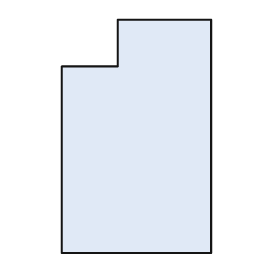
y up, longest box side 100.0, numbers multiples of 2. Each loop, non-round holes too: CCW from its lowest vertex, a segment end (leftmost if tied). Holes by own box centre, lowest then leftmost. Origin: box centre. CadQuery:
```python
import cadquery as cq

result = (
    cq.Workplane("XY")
    .moveTo(-32.0, -50.0)
    .lineTo(32.0, -50.0)
    .lineTo(32.0, 50.0)
    .lineTo(-8.0, 50.0)
    .lineTo(-8.0, 30.0)
    .lineTo(-32.0, 30.0)
    .close()
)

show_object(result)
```